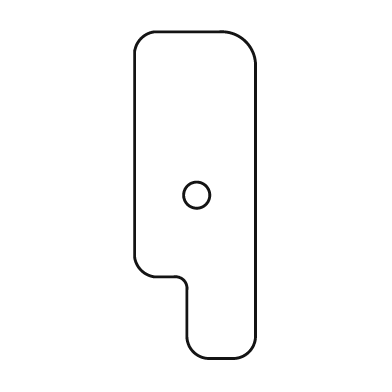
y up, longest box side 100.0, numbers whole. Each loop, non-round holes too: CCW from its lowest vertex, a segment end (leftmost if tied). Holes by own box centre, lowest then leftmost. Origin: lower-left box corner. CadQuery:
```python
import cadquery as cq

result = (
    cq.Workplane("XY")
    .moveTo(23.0, 0.0)
    .lineTo(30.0, 0.0)
    .threePointArc((35.0, 2.0), (37.0, 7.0))
    .lineTo(37.0, 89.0)
    .threePointArc((34.0, 97.0), (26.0, 100.0))
    .lineTo(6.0, 100.0)
    .threePointArc((2.0, 98.0), (0.0, 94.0))
    .lineTo(0.0, 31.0)
    .threePointArc((2.0, 27.0), (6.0, 25.0))
    .lineTo(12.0, 25.0)
    .threePointArc((15.0, 24.0), (16.0, 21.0))
    .lineTo(16.0, 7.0)
    .threePointArc((18.0, 2.0), (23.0, 0.0))
    .close()
    .moveTo(19.0, 50.0)
    .circle(4.0)
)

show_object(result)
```